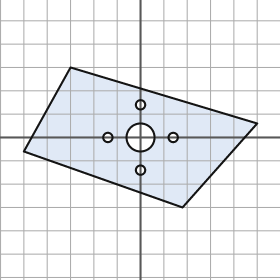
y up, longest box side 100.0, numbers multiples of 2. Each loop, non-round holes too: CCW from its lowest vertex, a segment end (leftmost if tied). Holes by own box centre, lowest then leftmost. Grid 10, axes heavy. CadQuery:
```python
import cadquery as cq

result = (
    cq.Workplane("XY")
    .moveTo(18.0, -30.0)
    .lineTo(50.0, 6.0)
    .lineTo(-30.0, 30.0)
    .lineTo(-50.0, -6.0)
    .close()
    .moveTo(0.0, -14.0)
    .circle(2.0)
    .moveTo(-14.0, 0.0)
    .circle(2.0)
    .moveTo(0.0, 0.0)
    .circle(6.0)
    .moveTo(14.0, 0.0)
    .circle(2.0)
    .moveTo(0.0, 14.0)
    .circle(2.0)
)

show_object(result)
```